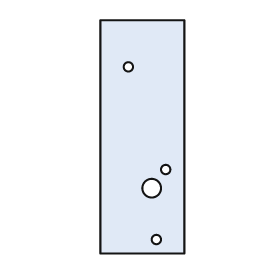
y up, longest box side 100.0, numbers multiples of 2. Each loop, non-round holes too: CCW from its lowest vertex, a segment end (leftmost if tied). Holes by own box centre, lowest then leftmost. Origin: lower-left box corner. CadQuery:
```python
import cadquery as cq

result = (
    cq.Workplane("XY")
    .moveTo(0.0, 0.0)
    .lineTo(36.0, 0.0)
    .lineTo(36.0, 100.0)
    .lineTo(0.0, 100.0)
    .close()
    .moveTo(24.0, 6.0)
    .circle(2.0)
    .moveTo(22.0, 28.0)
    .circle(4.0)
    .moveTo(28.0, 36.0)
    .circle(2.0)
    .moveTo(12.0, 80.0)
    .circle(2.0)
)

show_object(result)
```